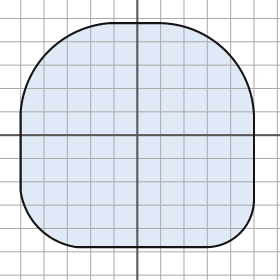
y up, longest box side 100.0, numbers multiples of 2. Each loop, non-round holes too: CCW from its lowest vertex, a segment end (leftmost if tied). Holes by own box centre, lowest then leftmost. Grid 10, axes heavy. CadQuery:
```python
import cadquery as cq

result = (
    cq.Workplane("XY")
    .moveTo(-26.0, -48.0)
    .lineTo(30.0, -48.0)
    .threePointArc((44.0, -42.0), (50.0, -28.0))
    .lineTo(50.0, 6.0)
    .threePointArc((38.0, 36.0), (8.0, 48.0))
    .lineTo(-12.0, 48.0)
    .threePointArc((-38.0, 36.0), (-50.0, 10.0))
    .lineTo(-50.0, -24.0)
    .threePointArc((-42.0, -40.0), (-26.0, -48.0))
    .close()
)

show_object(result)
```